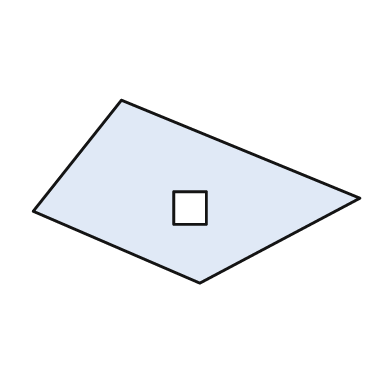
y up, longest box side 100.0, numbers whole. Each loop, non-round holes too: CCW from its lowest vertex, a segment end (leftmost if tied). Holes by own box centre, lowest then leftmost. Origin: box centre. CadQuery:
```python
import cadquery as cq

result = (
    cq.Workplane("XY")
    .moveTo(1.0, -28.0)
    .lineTo(50.0, -2.0)
    .lineTo(-23.0, 28.0)
    .lineTo(-50.0, -6.0)
    .close()
    .moveTo(-7.0, -10.0)
    .lineTo(3.0, -10.0)
    .lineTo(3.0, 0.0)
    .lineTo(-7.0, 0.0)
    .close()
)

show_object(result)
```